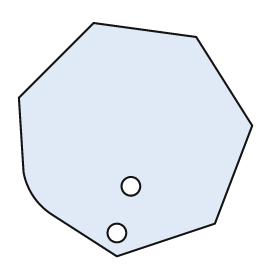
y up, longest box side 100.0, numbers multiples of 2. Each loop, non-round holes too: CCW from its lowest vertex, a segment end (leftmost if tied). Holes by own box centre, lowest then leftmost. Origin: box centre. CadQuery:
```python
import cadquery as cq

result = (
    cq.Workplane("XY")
    .moveTo(-8.0, -50.0)
    .lineTo(34.0, -36.0)
    .lineTo(50.0, 6.0)
    .lineTo(26.0, 44.0)
    .lineTo(-18.0, 50.0)
    .lineTo(-50.0, 18.0)
    .lineTo(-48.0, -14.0)
    .threePointArc((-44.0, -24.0), (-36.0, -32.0))
    .close()
    .moveTo(-8.0, -40.0)
    .circle(4.0)
    .moveTo(-2.0, -20.0)
    .circle(4.0)
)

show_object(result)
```